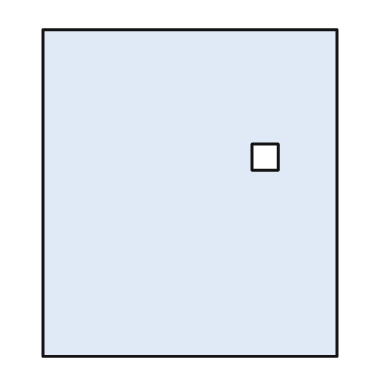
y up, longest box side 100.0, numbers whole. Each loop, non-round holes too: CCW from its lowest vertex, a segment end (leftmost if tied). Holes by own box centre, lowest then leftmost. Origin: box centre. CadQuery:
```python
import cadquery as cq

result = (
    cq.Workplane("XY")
    .moveTo(-45.0, -50.0)
    .lineTo(45.0, -50.0)
    .lineTo(45.0, 50.0)
    .lineTo(-45.0, 50.0)
    .close()
    .moveTo(19.0, 7.0)
    .lineTo(27.0, 7.0)
    .lineTo(27.0, 15.0)
    .lineTo(19.0, 15.0)
    .close()
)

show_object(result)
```